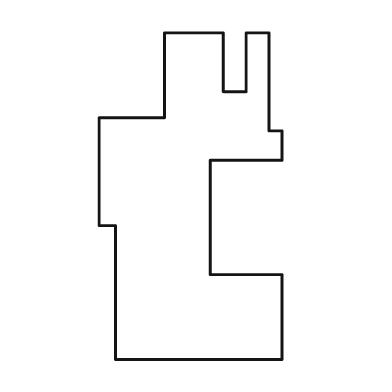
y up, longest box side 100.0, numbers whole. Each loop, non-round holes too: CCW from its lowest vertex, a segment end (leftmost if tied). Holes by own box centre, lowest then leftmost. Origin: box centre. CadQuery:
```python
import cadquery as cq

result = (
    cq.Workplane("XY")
    .moveTo(-23.0, -50.0)
    .lineTo(28.0, -50.0)
    .lineTo(28.0, -24.0)
    .lineTo(6.0, -24.0)
    .lineTo(6.0, 11.0)
    .lineTo(28.0, 11.0)
    .lineTo(28.0, 20.0)
    .lineTo(24.0, 20.0)
    .lineTo(24.0, 50.0)
    .lineTo(17.0, 50.0)
    .lineTo(17.0, 32.0)
    .lineTo(10.0, 32.0)
    .lineTo(10.0, 50.0)
    .lineTo(-8.0, 50.0)
    .lineTo(-8.0, 24.0)
    .lineTo(-28.0, 24.0)
    .lineTo(-28.0, -9.0)
    .lineTo(-23.0, -9.0)
    .close()
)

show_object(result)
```